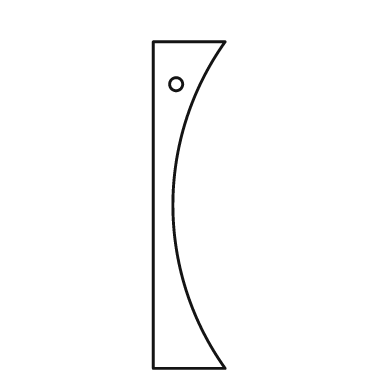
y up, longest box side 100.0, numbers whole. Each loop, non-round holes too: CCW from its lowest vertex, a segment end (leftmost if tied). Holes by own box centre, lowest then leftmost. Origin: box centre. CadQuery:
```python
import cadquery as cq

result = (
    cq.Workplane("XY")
    .moveTo(-11.0, -50.0)
    .lineTo(11.0, -50.0)
    .threePointArc((-5.0, 0.0), (11.0, 50.0))
    .lineTo(-11.0, 50.0)
    .close()
    .moveTo(-4.0, 37.0)
    .circle(2.0)
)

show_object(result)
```